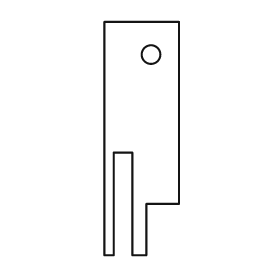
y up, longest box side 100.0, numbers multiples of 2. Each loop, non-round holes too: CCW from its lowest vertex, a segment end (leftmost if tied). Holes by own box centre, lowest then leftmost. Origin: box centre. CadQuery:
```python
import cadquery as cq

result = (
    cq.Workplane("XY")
    .moveTo(-16.0, -50.0)
    .lineTo(-12.0, -50.0)
    .lineTo(-12.0, -6.0)
    .lineTo(-4.0, -6.0)
    .lineTo(-4.0, -50.0)
    .lineTo(2.0, -50.0)
    .lineTo(2.0, -28.0)
    .lineTo(16.0, -28.0)
    .lineTo(16.0, 50.0)
    .lineTo(-16.0, 50.0)
    .close()
    .moveTo(4.0, 36.0)
    .circle(4.0)
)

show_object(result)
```